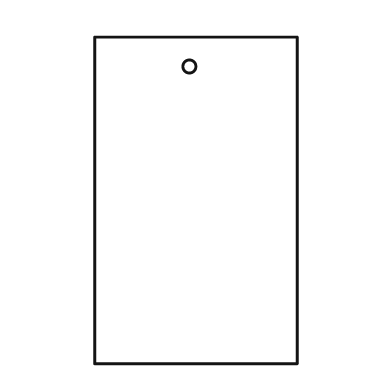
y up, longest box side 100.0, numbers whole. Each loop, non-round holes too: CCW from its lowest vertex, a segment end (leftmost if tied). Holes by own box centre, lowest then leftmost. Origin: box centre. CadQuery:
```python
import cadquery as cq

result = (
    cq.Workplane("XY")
    .moveTo(-31.0, -50.0)
    .lineTo(31.0, -50.0)
    .lineTo(31.0, 50.0)
    .lineTo(-31.0, 50.0)
    .close()
    .moveTo(-2.0, 41.0)
    .circle(2.0)
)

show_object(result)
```